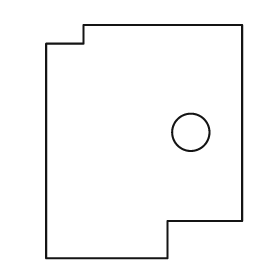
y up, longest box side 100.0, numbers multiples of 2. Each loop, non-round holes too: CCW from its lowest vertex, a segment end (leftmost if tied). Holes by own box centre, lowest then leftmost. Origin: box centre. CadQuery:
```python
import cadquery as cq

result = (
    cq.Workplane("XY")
    .moveTo(-42.0, -50.0)
    .lineTo(10.0, -50.0)
    .lineTo(10.0, -34.0)
    .lineTo(42.0, -34.0)
    .lineTo(42.0, 50.0)
    .lineTo(-26.0, 50.0)
    .lineTo(-26.0, 42.0)
    .lineTo(-42.0, 42.0)
    .close()
    .moveTo(20.0, 4.0)
    .circle(8.0)
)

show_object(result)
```